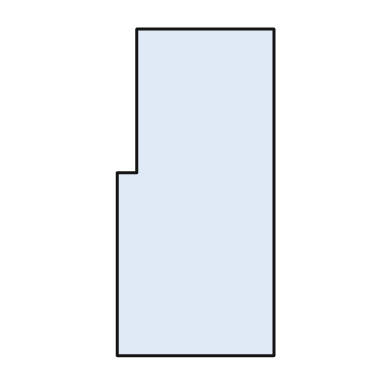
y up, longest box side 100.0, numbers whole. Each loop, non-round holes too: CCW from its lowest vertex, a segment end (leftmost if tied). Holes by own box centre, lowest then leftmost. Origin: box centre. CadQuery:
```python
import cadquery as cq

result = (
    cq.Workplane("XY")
    .moveTo(-24.0, -50.0)
    .lineTo(24.0, -50.0)
    .lineTo(24.0, 50.0)
    .lineTo(-18.0, 50.0)
    .lineTo(-18.0, 6.0)
    .lineTo(-24.0, 6.0)
    .close()
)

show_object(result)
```